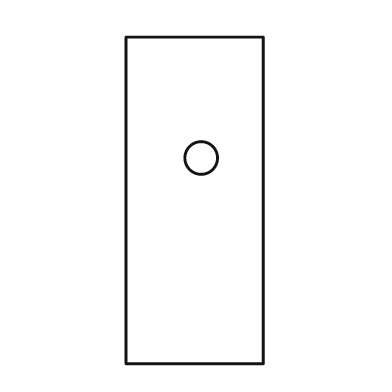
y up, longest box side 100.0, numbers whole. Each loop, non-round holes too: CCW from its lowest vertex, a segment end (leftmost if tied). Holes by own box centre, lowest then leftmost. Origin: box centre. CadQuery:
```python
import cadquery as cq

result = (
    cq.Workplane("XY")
    .moveTo(-21.0, -50.0)
    .lineTo(21.0, -50.0)
    .lineTo(21.0, 50.0)
    .lineTo(-21.0, 50.0)
    .close()
    .moveTo(2.0, 13.0)
    .circle(5.0)
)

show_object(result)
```